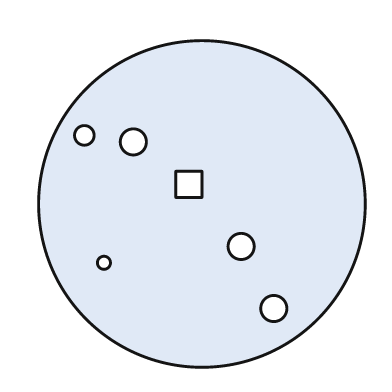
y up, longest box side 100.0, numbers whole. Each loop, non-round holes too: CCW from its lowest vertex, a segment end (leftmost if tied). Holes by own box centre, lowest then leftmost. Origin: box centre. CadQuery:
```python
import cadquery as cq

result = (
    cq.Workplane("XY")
    .moveTo(0.0, 0.0)
    .circle(50.0)
    .moveTo(22.0, -32.0)
    .circle(4.0)
    .moveTo(-30.0, -18.0)
    .circle(2.0)
    .moveTo(12.0, -13.0)
    .circle(4.0)
    .moveTo(-8.0, 2.0)
    .lineTo(0.0, 2.0)
    .lineTo(0.0, 10.0)
    .lineTo(-8.0, 10.0)
    .close()
    .moveTo(-21.0, 19.0)
    .circle(4.0)
    .moveTo(-36.0, 21.0)
    .circle(3.0)
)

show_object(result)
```